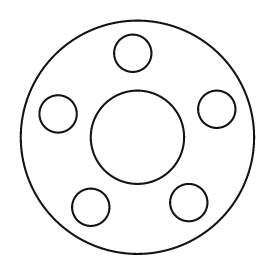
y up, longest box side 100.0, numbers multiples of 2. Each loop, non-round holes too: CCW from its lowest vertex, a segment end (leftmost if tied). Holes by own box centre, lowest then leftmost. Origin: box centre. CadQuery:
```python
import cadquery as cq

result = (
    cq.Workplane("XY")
    .moveTo(0.0, 0.0)
    .circle(50.0)
    .moveTo(-20.0, -30.0)
    .circle(8.0)
    .moveTo(22.0, -28.0)
    .circle(8.0)
    .moveTo(0.0, 0.0)
    .circle(20.0)
    .moveTo(-34.0, 10.0)
    .circle(8.0)
    .moveTo(34.0, 12.0)
    .circle(8.0)
    .moveTo(-2.0, 36.0)
    .circle(8.0)
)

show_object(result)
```